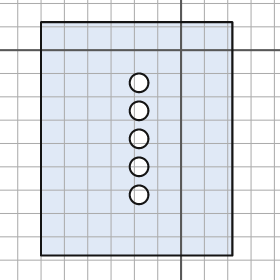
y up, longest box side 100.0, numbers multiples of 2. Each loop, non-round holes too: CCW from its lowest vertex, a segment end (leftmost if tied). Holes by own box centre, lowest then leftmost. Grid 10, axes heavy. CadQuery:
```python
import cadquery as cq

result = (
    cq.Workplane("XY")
    .moveTo(-60.0, -88.0)
    .lineTo(22.0, -88.0)
    .lineTo(22.0, 12.0)
    .lineTo(-60.0, 12.0)
    .close()
    .moveTo(-18.0, -62.0)
    .circle(4.0)
    .moveTo(-18.0, -50.0)
    .circle(4.0)
    .moveTo(-18.0, -38.0)
    .circle(4.0)
    .moveTo(-18.0, -26.0)
    .circle(4.0)
    .moveTo(-18.0, -14.0)
    .circle(4.0)
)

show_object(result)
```